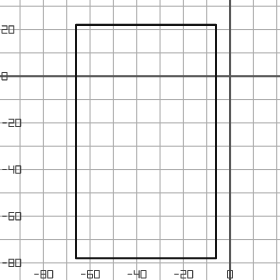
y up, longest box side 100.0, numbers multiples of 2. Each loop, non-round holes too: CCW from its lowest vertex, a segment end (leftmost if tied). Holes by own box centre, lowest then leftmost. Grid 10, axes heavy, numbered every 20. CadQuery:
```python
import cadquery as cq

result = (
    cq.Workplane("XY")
    .moveTo(-66.0, -78.0)
    .lineTo(-6.0, -78.0)
    .lineTo(-6.0, 22.0)
    .lineTo(-66.0, 22.0)
    .close()
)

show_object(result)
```